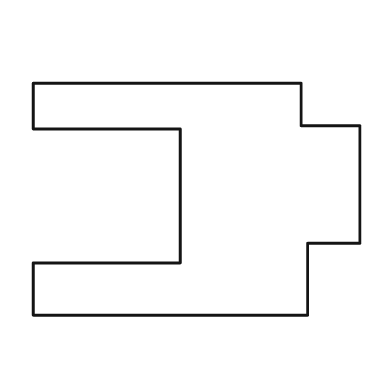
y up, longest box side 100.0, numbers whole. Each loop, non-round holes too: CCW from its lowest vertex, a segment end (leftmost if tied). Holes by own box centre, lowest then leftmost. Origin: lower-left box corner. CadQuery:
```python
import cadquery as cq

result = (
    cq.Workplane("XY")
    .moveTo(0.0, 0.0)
    .lineTo(84.0, 0.0)
    .lineTo(84.0, 22.0)
    .lineTo(100.0, 22.0)
    .lineTo(100.0, 58.0)
    .lineTo(82.0, 58.0)
    .lineTo(82.0, 71.0)
    .lineTo(0.0, 71.0)
    .lineTo(0.0, 57.0)
    .lineTo(45.0, 57.0)
    .lineTo(45.0, 16.0)
    .lineTo(0.0, 16.0)
    .close()
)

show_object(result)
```